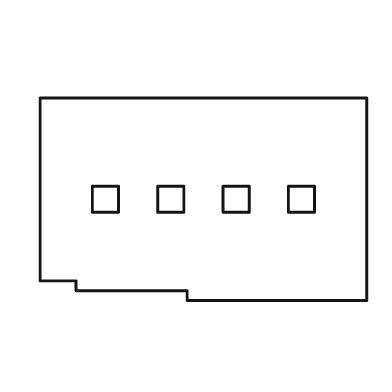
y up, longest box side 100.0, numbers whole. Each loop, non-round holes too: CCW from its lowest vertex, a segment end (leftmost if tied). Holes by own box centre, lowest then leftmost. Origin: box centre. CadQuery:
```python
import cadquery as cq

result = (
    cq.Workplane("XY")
    .moveTo(-5.0, -31.0)
    .lineTo(50.0, -31.0)
    .lineTo(50.0, 31.0)
    .lineTo(-50.0, 31.0)
    .lineTo(-50.0, -25.0)
    .lineTo(-39.0, -25.0)
    .lineTo(-39.0, -28.0)
    .lineTo(-5.0, -28.0)
    .close()
    .moveTo(-34.0, -4.0)
    .lineTo(-26.0, -4.0)
    .lineTo(-26.0, 4.0)
    .lineTo(-34.0, 4.0)
    .close()
    .moveTo(-14.0, -4.0)
    .lineTo(-6.0, -4.0)
    .lineTo(-6.0, 4.0)
    .lineTo(-14.0, 4.0)
    .close()
    .moveTo(6.0, -4.0)
    .lineTo(14.0, -4.0)
    .lineTo(14.0, 4.0)
    .lineTo(6.0, 4.0)
    .close()
    .moveTo(26.0, -4.0)
    .lineTo(34.0, -4.0)
    .lineTo(34.0, 4.0)
    .lineTo(26.0, 4.0)
    .close()
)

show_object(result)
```